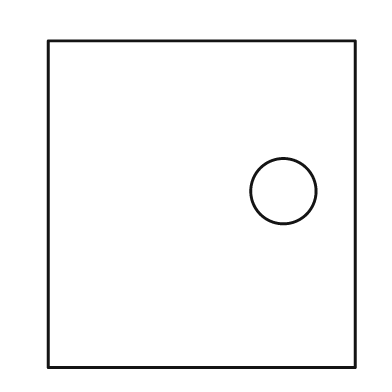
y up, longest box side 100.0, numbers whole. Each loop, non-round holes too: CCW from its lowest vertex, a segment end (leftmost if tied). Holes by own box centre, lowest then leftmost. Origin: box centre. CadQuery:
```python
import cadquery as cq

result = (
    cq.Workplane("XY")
    .moveTo(-47.0, -50.0)
    .lineTo(47.0, -50.0)
    .lineTo(47.0, 50.0)
    .lineTo(-47.0, 50.0)
    .close()
    .moveTo(25.0, 4.0)
    .circle(10.0)
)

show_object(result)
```